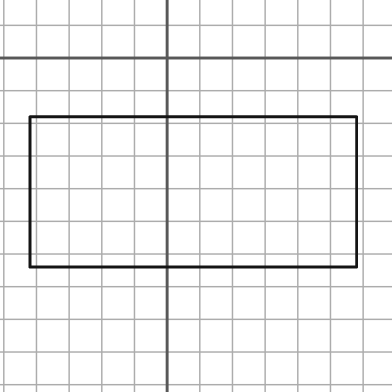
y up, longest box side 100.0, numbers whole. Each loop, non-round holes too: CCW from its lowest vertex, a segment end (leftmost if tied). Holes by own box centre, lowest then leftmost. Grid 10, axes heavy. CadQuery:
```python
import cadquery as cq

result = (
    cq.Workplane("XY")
    .moveTo(-42.0, -64.0)
    .lineTo(58.0, -64.0)
    .lineTo(58.0, -18.0)
    .lineTo(-42.0, -18.0)
    .close()
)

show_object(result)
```